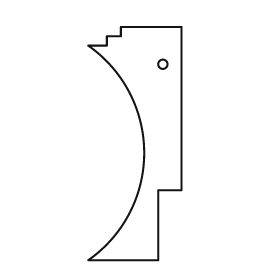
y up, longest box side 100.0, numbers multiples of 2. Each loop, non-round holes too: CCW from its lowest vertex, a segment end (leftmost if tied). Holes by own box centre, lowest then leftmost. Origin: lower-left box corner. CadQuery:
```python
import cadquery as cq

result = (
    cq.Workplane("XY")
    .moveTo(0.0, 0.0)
    .lineTo(30.0, 0.0)
    .lineTo(30.0, 30.0)
    .lineTo(40.0, 30.0)
    .lineTo(40.0, 100.0)
    .lineTo(14.0, 100.0)
    .lineTo(14.0, 96.0)
    .lineTo(8.0, 96.0)
    .lineTo(8.0, 92.0)
    .lineTo(0.0, 92.0)
    .threePointArc((24.0, 46.0), (0.0, 0.0))
    .close()
    .moveTo(32.0, 84.0)
    .circle(2.0)
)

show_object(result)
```